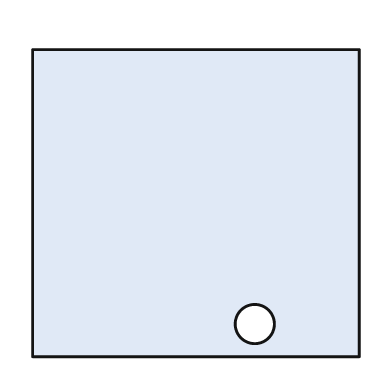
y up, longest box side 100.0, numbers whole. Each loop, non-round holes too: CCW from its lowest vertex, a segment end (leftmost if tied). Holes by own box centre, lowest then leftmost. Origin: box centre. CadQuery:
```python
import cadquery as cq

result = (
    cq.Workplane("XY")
    .moveTo(-50.0, -47.0)
    .lineTo(50.0, -47.0)
    .lineTo(50.0, 47.0)
    .lineTo(-50.0, 47.0)
    .close()
    .moveTo(18.0, -37.0)
    .circle(6.0)
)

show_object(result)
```